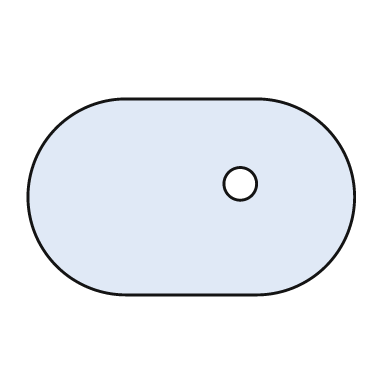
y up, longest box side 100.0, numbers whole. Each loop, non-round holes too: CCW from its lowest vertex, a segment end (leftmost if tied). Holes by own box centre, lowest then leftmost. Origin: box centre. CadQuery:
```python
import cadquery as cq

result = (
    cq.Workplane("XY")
    .moveTo(-20.0, -30.0)
    .lineTo(20.0, -30.0)
    .threePointArc((50.0, 0.0), (20.0, 30.0))
    .lineTo(-20.0, 30.0)
    .threePointArc((-50.0, 0.0), (-20.0, -30.0))
    .close()
    .moveTo(15.0, 4.0)
    .circle(5.0)
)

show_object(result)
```